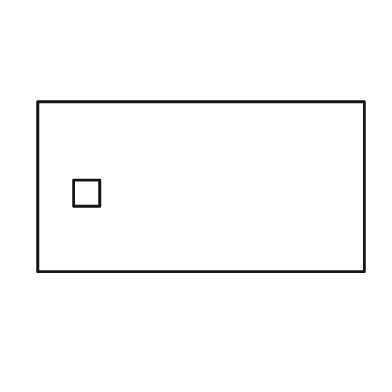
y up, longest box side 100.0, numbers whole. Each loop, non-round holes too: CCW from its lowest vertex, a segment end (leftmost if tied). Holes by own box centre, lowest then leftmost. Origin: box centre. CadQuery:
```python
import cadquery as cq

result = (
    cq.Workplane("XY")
    .moveTo(-50.0, -26.0)
    .lineTo(50.0, -26.0)
    .lineTo(50.0, 26.0)
    .lineTo(-50.0, 26.0)
    .close()
    .moveTo(-39.0, -6.0)
    .lineTo(-31.0, -6.0)
    .lineTo(-31.0, 2.0)
    .lineTo(-39.0, 2.0)
    .close()
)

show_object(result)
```